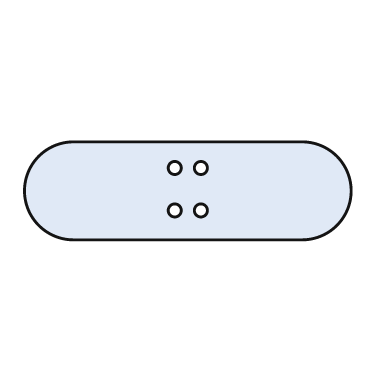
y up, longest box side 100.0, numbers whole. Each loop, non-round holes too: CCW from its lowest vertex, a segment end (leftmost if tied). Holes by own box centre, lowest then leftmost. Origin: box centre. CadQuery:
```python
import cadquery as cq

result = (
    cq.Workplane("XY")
    .moveTo(-35.0, -15.0)
    .lineTo(35.0, -15.0)
    .threePointArc((50.0, 0.0), (35.0, 15.0))
    .lineTo(-35.0, 15.0)
    .threePointArc((-50.0, 0.0), (-35.0, -15.0))
    .close()
    .moveTo(-4.0, -6.0)
    .circle(2.0)
    .moveTo(4.0, -6.0)
    .circle(2.0)
    .moveTo(-4.0, 7.0)
    .circle(2.0)
    .moveTo(4.0, 7.0)
    .circle(2.0)
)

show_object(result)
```